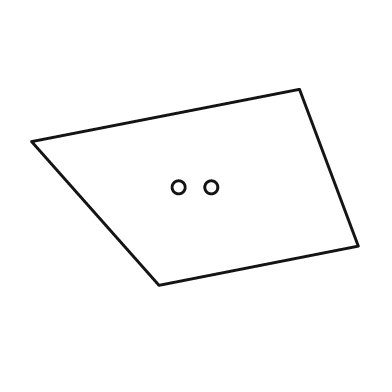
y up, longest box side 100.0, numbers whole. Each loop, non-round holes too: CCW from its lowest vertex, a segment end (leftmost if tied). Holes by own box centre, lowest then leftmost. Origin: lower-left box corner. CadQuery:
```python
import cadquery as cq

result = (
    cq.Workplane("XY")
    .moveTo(39.0, 0.0)
    .lineTo(100.0, 12.0)
    .lineTo(82.0, 60.0)
    .lineTo(0.0, 44.0)
    .close()
    .moveTo(45.0, 30.0)
    .circle(2.0)
    .moveTo(55.0, 30.0)
    .circle(2.0)
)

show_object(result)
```